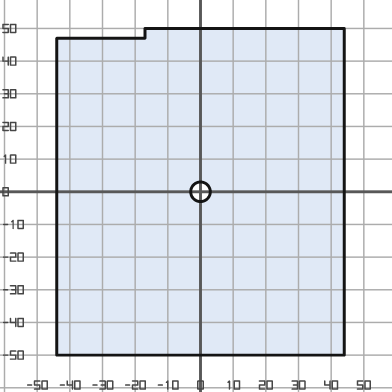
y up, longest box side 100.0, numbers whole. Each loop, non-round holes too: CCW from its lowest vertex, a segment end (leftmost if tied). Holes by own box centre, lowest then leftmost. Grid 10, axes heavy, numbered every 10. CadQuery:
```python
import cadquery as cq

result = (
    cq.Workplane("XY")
    .moveTo(-44.0, -50.0)
    .lineTo(44.0, -50.0)
    .lineTo(44.0, 50.0)
    .lineTo(-17.0, 50.0)
    .lineTo(-17.0, 47.0)
    .lineTo(-44.0, 47.0)
    .close()
    .moveTo(0.0, 0.0)
    .circle(3.0)
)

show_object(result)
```